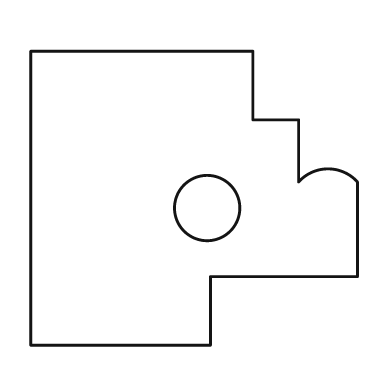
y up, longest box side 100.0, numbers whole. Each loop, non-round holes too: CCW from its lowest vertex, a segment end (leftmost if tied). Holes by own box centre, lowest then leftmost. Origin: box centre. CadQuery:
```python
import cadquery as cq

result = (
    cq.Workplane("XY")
    .moveTo(-50.0, -45.0)
    .lineTo(5.0, -45.0)
    .lineTo(5.0, -24.0)
    .lineTo(50.0, -24.0)
    .lineTo(50.0, 5.0)
    .threePointArc((41.0, 9.0), (32.0, 5.0))
    .lineTo(32.0, 24.0)
    .lineTo(18.0, 24.0)
    .lineTo(18.0, 45.0)
    .lineTo(-50.0, 45.0)
    .close()
    .moveTo(4.0, -3.0)
    .circle(10.0)
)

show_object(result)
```